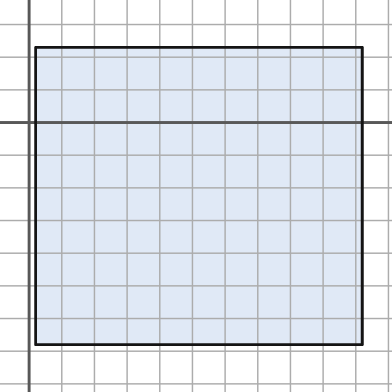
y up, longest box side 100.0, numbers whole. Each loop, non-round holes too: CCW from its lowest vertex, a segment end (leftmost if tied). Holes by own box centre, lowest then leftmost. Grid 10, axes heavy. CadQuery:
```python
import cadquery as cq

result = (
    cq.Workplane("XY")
    .moveTo(2.0, -68.0)
    .lineTo(102.0, -68.0)
    .lineTo(102.0, 23.0)
    .lineTo(2.0, 23.0)
    .close()
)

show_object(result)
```